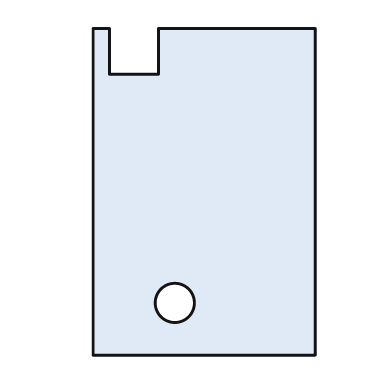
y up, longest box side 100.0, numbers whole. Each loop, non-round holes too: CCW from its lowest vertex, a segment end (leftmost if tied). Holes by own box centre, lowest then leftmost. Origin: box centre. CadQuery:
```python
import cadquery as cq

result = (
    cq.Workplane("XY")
    .moveTo(-34.0, -50.0)
    .lineTo(34.0, -50.0)
    .lineTo(34.0, 50.0)
    .lineTo(-14.0, 50.0)
    .lineTo(-14.0, 36.0)
    .lineTo(-29.0, 36.0)
    .lineTo(-29.0, 50.0)
    .lineTo(-34.0, 50.0)
    .close()
    .moveTo(-9.0, -34.0)
    .circle(6.0)
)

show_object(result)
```